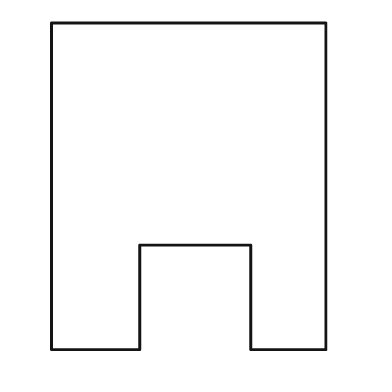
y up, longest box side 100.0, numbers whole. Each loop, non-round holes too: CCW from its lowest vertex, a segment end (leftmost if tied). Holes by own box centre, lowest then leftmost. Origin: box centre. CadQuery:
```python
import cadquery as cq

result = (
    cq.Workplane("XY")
    .moveTo(-42.0, -50.0)
    .lineTo(-15.0, -50.0)
    .lineTo(-15.0, -18.0)
    .lineTo(19.0, -18.0)
    .lineTo(19.0, -50.0)
    .lineTo(42.0, -50.0)
    .lineTo(42.0, 50.0)
    .lineTo(-42.0, 50.0)
    .close()
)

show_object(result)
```